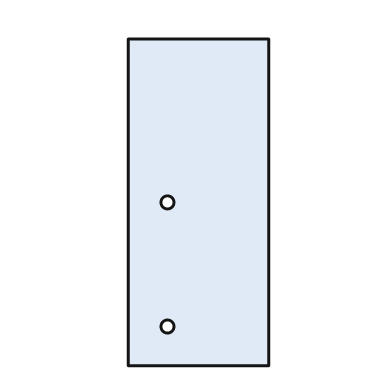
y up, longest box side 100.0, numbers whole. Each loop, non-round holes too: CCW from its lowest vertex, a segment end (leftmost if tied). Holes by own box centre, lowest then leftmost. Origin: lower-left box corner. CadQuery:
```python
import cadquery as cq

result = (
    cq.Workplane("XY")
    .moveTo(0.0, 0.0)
    .lineTo(43.0, 0.0)
    .lineTo(43.0, 100.0)
    .lineTo(0.0, 100.0)
    .close()
    .moveTo(12.0, 12.0)
    .circle(2.0)
    .moveTo(12.0, 50.0)
    .circle(2.0)
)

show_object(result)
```